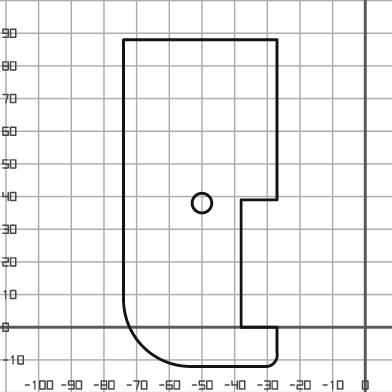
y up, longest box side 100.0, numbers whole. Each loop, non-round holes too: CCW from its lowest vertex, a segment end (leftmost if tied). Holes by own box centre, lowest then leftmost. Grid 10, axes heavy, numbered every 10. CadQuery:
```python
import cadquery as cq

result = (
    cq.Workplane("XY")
    .moveTo(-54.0, -12.0)
    .lineTo(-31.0, -12.0)
    .threePointArc((-28.0, -11.0), (-27.0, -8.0))
    .lineTo(-27.0, 0.0)
    .lineTo(-38.0, 0.0)
    .lineTo(-38.0, 39.0)
    .lineTo(-27.0, 39.0)
    .lineTo(-27.0, 88.0)
    .lineTo(-74.0, 88.0)
    .lineTo(-74.0, 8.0)
    .threePointArc((-68.0, -6.0), (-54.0, -12.0))
    .close()
    .moveTo(-50.0, 38.0)
    .circle(3.0)
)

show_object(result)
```